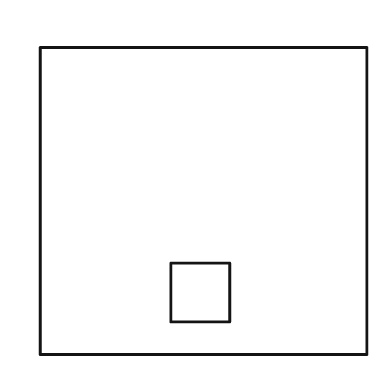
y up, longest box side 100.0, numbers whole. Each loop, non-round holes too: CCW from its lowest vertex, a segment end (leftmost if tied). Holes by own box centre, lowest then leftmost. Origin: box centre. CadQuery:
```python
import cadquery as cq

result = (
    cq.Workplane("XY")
    .moveTo(-50.0, -47.0)
    .lineTo(50.0, -47.0)
    .lineTo(50.0, 47.0)
    .lineTo(-50.0, 47.0)
    .close()
    .moveTo(-10.0, -37.0)
    .lineTo(8.0, -37.0)
    .lineTo(8.0, -19.0)
    .lineTo(-10.0, -19.0)
    .close()
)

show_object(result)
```